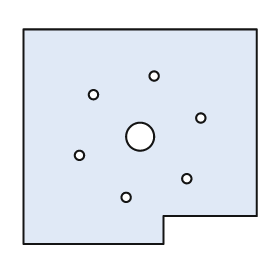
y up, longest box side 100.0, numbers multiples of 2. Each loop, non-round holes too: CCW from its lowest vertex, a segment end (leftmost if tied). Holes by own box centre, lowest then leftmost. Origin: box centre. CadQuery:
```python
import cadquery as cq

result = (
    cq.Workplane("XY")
    .moveTo(-50.0, -46.0)
    .lineTo(10.0, -46.0)
    .lineTo(10.0, -34.0)
    .lineTo(50.0, -34.0)
    .lineTo(50.0, 46.0)
    .lineTo(-50.0, 46.0)
    .close()
    .moveTo(-6.0, -26.0)
    .circle(2.0)
    .moveTo(20.0, -18.0)
    .circle(2.0)
    .moveTo(-26.0, -8.0)
    .circle(2.0)
    .moveTo(0.0, 0.0)
    .circle(6.0)
    .moveTo(26.0, 8.0)
    .circle(2.0)
    .moveTo(-20.0, 18.0)
    .circle(2.0)
    .moveTo(6.0, 26.0)
    .circle(2.0)
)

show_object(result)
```